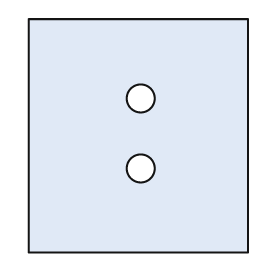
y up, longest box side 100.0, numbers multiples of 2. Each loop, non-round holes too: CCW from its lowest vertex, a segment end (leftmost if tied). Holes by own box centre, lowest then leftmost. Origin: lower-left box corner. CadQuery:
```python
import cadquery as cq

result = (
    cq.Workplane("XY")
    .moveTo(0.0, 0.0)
    .lineTo(94.0, 0.0)
    .lineTo(94.0, 100.0)
    .lineTo(0.0, 100.0)
    .close()
    .moveTo(48.0, 36.0)
    .circle(6.0)
    .moveTo(48.0, 66.0)
    .circle(6.0)
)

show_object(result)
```